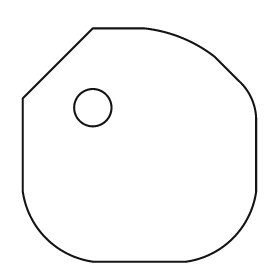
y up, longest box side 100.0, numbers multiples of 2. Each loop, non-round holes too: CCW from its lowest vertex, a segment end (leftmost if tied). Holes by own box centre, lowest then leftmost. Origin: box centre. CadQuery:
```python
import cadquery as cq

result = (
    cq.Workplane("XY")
    .moveTo(-20.0, -50.0)
    .lineTo(20.0, -50.0)
    .threePointArc((40.0, -40.0), (50.0, -20.0))
    .lineTo(50.0, 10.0)
    .threePointArc((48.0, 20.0), (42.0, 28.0))
    .lineTo(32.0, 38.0)
    .threePointArc((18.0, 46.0), (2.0, 50.0))
    .lineTo(-20.0, 50.0)
    .lineTo(-50.0, 20.0)
    .lineTo(-50.0, -20.0)
    .threePointArc((-40.0, -40.0), (-20.0, -50.0))
    .close()
    .moveTo(-20.0, 16.0)
    .circle(8.0)
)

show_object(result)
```